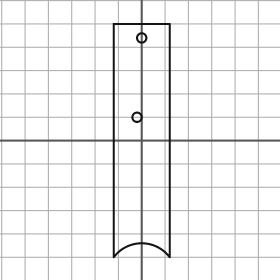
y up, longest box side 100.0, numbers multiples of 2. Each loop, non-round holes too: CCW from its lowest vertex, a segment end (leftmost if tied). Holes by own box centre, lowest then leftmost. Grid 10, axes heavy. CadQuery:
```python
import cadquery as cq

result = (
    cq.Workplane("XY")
    .moveTo(-12.0, -50.0)
    .threePointArc((0.0, -44.0), (12.0, -50.0))
    .lineTo(12.0, 50.0)
    .lineTo(-12.0, 50.0)
    .close()
    .moveTo(-2.0, 10.0)
    .circle(2.0)
    .moveTo(0.0, 44.0)
    .circle(2.0)
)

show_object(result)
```